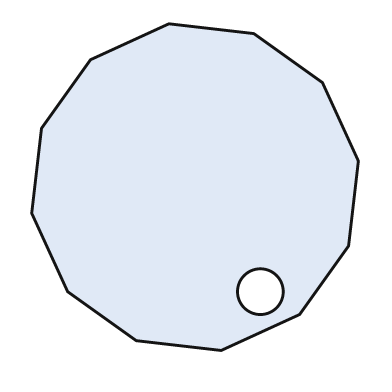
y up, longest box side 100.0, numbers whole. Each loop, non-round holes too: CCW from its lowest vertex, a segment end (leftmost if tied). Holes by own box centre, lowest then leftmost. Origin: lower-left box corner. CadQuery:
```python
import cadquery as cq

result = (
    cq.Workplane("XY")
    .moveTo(58.0, 0.0)
    .lineTo(82.0, 11.0)
    .lineTo(97.0, 32.0)
    .lineTo(100.0, 58.0)
    .lineTo(89.0, 82.0)
    .lineTo(68.0, 97.0)
    .lineTo(42.0, 100.0)
    .lineTo(18.0, 89.0)
    .lineTo(3.0, 68.0)
    .lineTo(0.0, 42.0)
    .lineTo(11.0, 18.0)
    .lineTo(32.0, 3.0)
    .close()
    .moveTo(70.0, 18.0)
    .circle(7.0)
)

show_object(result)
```